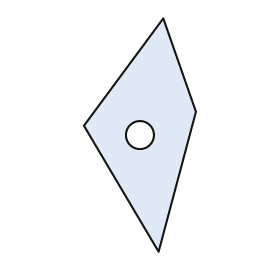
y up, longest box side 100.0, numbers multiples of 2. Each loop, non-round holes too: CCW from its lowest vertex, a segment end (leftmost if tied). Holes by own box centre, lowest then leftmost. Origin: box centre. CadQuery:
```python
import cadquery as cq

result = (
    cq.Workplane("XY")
    .moveTo(8.0, -50.0)
    .lineTo(24.0, 10.0)
    .lineTo(10.0, 50.0)
    .lineTo(-24.0, 4.0)
    .close()
    .moveTo(0.0, 0.0)
    .circle(6.0)
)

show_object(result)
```